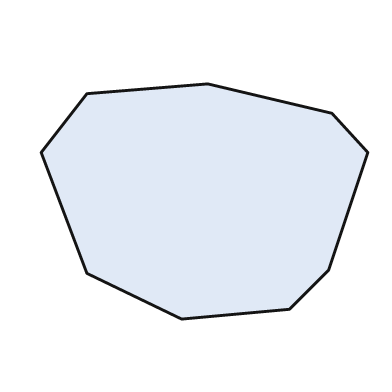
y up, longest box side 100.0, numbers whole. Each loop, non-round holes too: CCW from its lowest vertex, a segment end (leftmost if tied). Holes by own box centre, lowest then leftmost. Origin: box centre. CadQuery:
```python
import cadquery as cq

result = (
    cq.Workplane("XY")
    .moveTo(-7.0, -36.0)
    .lineTo(26.0, -33.0)
    .lineTo(38.0, -21.0)
    .lineTo(50.0, 15.0)
    .lineTo(39.0, 27.0)
    .lineTo(1.0, 36.0)
    .lineTo(-36.0, 33.0)
    .lineTo(-50.0, 15.0)
    .lineTo(-36.0, -22.0)
    .close()
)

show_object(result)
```